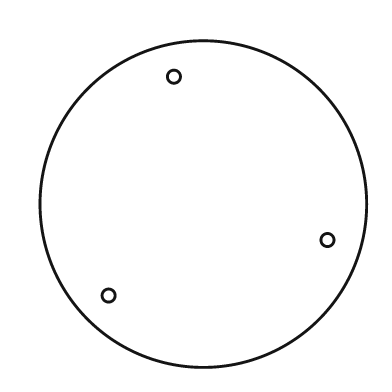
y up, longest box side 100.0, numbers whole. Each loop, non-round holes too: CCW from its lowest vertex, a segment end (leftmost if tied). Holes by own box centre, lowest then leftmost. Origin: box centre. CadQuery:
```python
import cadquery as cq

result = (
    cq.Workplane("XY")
    .moveTo(0.0, 0.0)
    .circle(50.0)
    .moveTo(-29.0, -28.0)
    .circle(2.0)
    .moveTo(38.0, -11.0)
    .circle(2.0)
    .moveTo(-9.0, 39.0)
    .circle(2.0)
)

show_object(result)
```